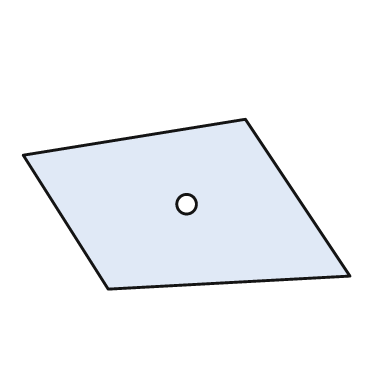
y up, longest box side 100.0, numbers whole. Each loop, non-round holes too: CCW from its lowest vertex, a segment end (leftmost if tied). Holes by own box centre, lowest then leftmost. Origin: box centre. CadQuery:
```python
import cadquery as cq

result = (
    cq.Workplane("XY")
    .moveTo(-24.0, -26.0)
    .lineTo(50.0, -22.0)
    .lineTo(18.0, 26.0)
    .lineTo(-50.0, 15.0)
    .close()
    .moveTo(0.0, 0.0)
    .circle(3.0)
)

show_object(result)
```